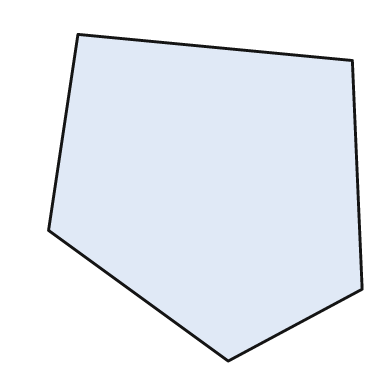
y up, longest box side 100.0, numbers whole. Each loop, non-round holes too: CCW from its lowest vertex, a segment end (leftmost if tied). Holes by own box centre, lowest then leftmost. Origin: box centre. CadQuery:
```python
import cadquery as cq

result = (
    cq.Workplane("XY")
    .moveTo(7.0, -50.0)
    .lineTo(48.0, -28.0)
    .lineTo(45.0, 42.0)
    .lineTo(-39.0, 50.0)
    .lineTo(-48.0, -10.0)
    .close()
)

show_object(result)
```